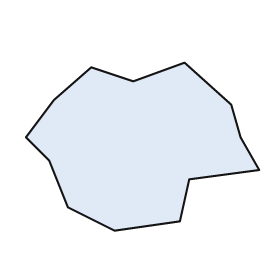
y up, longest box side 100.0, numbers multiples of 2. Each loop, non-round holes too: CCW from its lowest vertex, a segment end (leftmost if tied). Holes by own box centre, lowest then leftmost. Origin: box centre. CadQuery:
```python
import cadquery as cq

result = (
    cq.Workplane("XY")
    .moveTo(-12.0, -36.0)
    .lineTo(16.0, -32.0)
    .lineTo(20.0, -14.0)
    .lineTo(50.0, -10.0)
    .lineTo(42.0, 4.0)
    .lineTo(38.0, 18.0)
    .lineTo(18.0, 36.0)
    .lineTo(-4.0, 28.0)
    .lineTo(-22.0, 34.0)
    .lineTo(-38.0, 20.0)
    .lineTo(-50.0, 4.0)
    .lineTo(-40.0, -6.0)
    .lineTo(-32.0, -26.0)
    .close()
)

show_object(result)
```